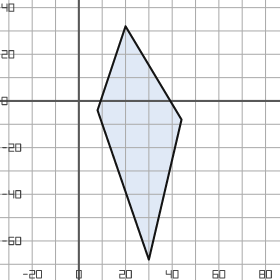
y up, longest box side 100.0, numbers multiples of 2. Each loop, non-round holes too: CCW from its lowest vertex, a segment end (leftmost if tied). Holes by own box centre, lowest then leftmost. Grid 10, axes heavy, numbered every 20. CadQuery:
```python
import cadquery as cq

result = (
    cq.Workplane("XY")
    .moveTo(30.0, -68.0)
    .lineTo(44.0, -8.0)
    .lineTo(20.0, 32.0)
    .lineTo(8.0, -4.0)
    .close()
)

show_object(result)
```